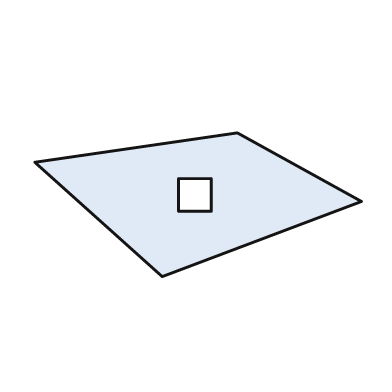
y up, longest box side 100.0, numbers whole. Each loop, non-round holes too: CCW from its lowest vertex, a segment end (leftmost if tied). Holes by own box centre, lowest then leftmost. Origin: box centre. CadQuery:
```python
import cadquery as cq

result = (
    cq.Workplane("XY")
    .moveTo(-11.0, -22.0)
    .lineTo(50.0, 1.0)
    .lineTo(12.0, 22.0)
    .lineTo(-50.0, 13.0)
    .close()
    .moveTo(-6.0, -2.0)
    .lineTo(4.0, -2.0)
    .lineTo(4.0, 8.0)
    .lineTo(-6.0, 8.0)
    .close()
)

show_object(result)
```